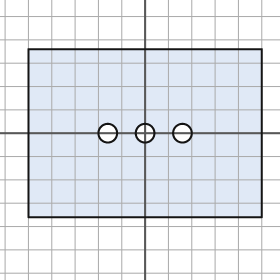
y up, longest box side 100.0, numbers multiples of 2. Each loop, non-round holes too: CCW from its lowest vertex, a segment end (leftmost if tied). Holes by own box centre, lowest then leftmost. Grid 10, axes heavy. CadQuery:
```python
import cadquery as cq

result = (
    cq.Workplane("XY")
    .moveTo(-50.0, -36.0)
    .lineTo(50.0, -36.0)
    .lineTo(50.0, 36.0)
    .lineTo(-50.0, 36.0)
    .close()
    .moveTo(-16.0, 0.0)
    .circle(4.0)
    .moveTo(0.0, 0.0)
    .circle(4.0)
    .moveTo(16.0, 0.0)
    .circle(4.0)
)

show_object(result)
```